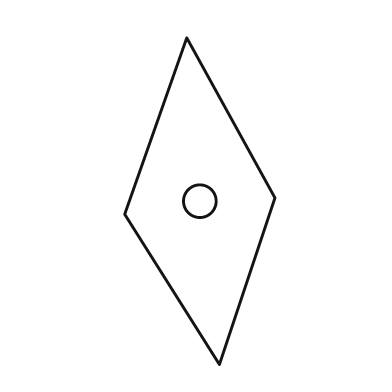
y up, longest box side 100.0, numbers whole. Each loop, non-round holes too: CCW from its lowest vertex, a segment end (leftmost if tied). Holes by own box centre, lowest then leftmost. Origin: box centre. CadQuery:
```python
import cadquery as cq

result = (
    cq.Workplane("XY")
    .moveTo(6.0, -50.0)
    .lineTo(23.0, 1.0)
    .lineTo(-4.0, 50.0)
    .lineTo(-23.0, -4.0)
    .close()
    .moveTo(0.0, 0.0)
    .circle(5.0)
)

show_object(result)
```